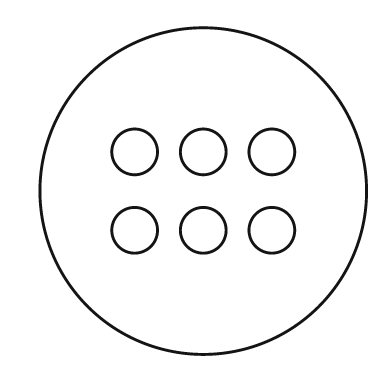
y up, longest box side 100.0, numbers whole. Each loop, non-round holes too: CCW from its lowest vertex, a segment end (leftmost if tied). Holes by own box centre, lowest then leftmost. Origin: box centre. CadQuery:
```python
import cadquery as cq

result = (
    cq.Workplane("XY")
    .moveTo(0.0, 0.0)
    .circle(50.0)
    .moveTo(-21.0, -12.0)
    .circle(7.0)
    .moveTo(0.0, -12.0)
    .circle(7.0)
    .moveTo(21.0, -12.0)
    .circle(7.0)
    .moveTo(-21.0, 12.0)
    .circle(7.0)
    .moveTo(0.0, 12.0)
    .circle(7.0)
    .moveTo(21.0, 12.0)
    .circle(7.0)
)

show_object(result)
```